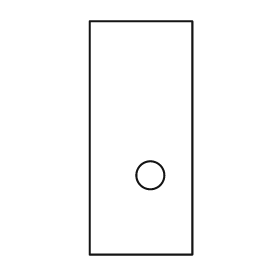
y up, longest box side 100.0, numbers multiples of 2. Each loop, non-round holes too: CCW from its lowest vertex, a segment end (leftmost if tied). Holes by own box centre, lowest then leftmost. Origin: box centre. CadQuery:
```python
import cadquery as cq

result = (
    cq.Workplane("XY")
    .moveTo(-22.0, -50.0)
    .lineTo(22.0, -50.0)
    .lineTo(22.0, 50.0)
    .lineTo(-22.0, 50.0)
    .close()
    .moveTo(4.0, -16.0)
    .circle(6.0)
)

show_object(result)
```